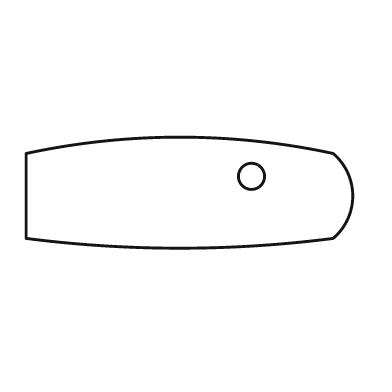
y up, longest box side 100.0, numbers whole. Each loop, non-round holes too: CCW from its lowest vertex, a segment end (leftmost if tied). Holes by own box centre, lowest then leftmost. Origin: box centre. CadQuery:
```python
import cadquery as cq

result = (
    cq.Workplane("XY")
    .moveTo(-50.0, -14.0)
    .threePointArc((-3.0, -17.0), (44.0, -14.0))
    .threePointArc((50.0, -1.0), (44.0, 12.0))
    .threePointArc((-3.0, 17.0), (-50.0, 12.0))
    .close()
    .moveTo(19.0, 5.0)
    .circle(4.0)
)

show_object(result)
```